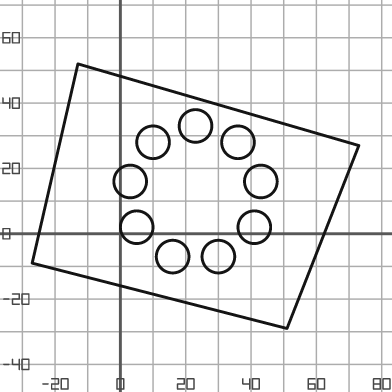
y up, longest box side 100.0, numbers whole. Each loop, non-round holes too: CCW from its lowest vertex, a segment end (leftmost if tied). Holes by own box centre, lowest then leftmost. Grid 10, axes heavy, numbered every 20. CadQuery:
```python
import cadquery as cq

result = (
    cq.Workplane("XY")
    .moveTo(51.0, -29.0)
    .lineTo(73.0, 27.0)
    .lineTo(-13.0, 52.0)
    .lineTo(-27.0, -9.0)
    .close()
    .moveTo(16.0, -7.0)
    .circle(5.0)
    .moveTo(30.0, -7.0)
    .circle(5.0)
    .moveTo(5.0, 2.0)
    .circle(5.0)
    .moveTo(41.0, 2.0)
    .circle(5.0)
    .moveTo(3.0, 16.0)
    .circle(5.0)
    .moveTo(43.0, 16.0)
    .circle(5.0)
    .moveTo(10.0, 28.0)
    .circle(5.0)
    .moveTo(36.0, 28.0)
    .circle(5.0)
    .moveTo(23.0, 33.0)
    .circle(5.0)
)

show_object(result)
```